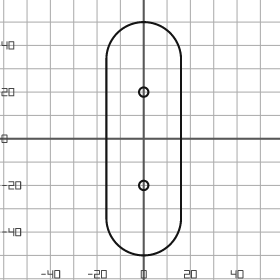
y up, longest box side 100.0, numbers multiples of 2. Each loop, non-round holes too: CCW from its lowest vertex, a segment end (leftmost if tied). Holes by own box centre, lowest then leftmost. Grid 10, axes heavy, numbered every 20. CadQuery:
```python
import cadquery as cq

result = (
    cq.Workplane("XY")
    .moveTo(-16.0, -34.0)
    .threePointArc((0.0, -50.0), (16.0, -34.0))
    .lineTo(16.0, 34.0)
    .threePointArc((0.0, 50.0), (-16.0, 34.0))
    .close()
    .moveTo(0.0, -20.0)
    .circle(2.0)
    .moveTo(0.0, 20.0)
    .circle(2.0)
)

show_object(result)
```